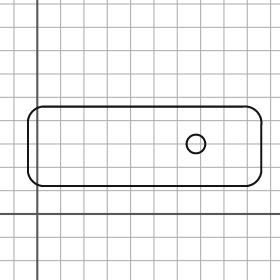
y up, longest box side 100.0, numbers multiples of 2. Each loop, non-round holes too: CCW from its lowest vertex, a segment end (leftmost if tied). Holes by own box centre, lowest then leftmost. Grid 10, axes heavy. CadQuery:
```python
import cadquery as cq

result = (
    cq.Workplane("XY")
    .moveTo(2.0, 12.0)
    .lineTo(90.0, 12.0)
    .threePointArc((94.0, 14.0), (96.0, 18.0))
    .lineTo(96.0, 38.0)
    .threePointArc((94.0, 44.0), (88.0, 46.0))
    .lineTo(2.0, 46.0)
    .threePointArc((-2.0, 44.0), (-4.0, 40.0))
    .lineTo(-4.0, 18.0)
    .threePointArc((-2.0, 14.0), (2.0, 12.0))
    .close()
    .moveTo(68.0, 30.0)
    .circle(4.0)
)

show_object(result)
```